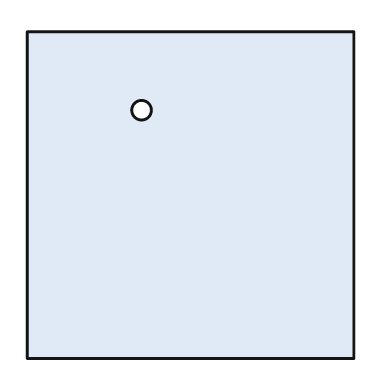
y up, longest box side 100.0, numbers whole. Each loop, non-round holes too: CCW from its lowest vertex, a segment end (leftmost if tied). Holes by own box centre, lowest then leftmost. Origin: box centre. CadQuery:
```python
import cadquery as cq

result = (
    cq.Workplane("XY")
    .moveTo(-50.0, -50.0)
    .lineTo(50.0, -50.0)
    .lineTo(50.0, 50.0)
    .lineTo(-50.0, 50.0)
    .close()
    .moveTo(-15.0, 26.0)
    .circle(3.0)
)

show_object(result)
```